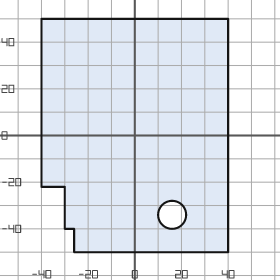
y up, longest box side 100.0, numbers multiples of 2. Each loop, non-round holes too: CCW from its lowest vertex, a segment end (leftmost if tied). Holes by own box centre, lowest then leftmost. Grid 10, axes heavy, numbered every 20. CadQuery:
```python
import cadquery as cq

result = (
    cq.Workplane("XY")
    .moveTo(-26.0, -50.0)
    .lineTo(40.0, -50.0)
    .lineTo(40.0, 50.0)
    .lineTo(-40.0, 50.0)
    .lineTo(-40.0, -22.0)
    .lineTo(-30.0, -22.0)
    .lineTo(-30.0, -40.0)
    .lineTo(-26.0, -40.0)
    .close()
    .moveTo(16.0, -34.0)
    .circle(6.0)
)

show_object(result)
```